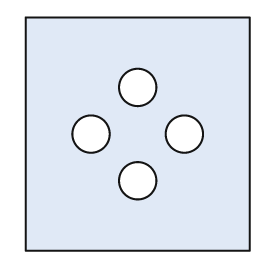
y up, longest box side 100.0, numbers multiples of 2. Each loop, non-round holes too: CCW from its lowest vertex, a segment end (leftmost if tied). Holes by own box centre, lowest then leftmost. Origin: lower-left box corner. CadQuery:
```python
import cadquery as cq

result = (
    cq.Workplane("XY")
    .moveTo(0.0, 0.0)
    .lineTo(96.0, 0.0)
    .lineTo(96.0, 100.0)
    .lineTo(0.0, 100.0)
    .close()
    .moveTo(48.0, 30.0)
    .circle(8.0)
    .moveTo(28.0, 50.0)
    .circle(8.0)
    .moveTo(68.0, 50.0)
    .circle(8.0)
    .moveTo(48.0, 70.0)
    .circle(8.0)
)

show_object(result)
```